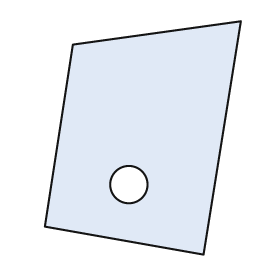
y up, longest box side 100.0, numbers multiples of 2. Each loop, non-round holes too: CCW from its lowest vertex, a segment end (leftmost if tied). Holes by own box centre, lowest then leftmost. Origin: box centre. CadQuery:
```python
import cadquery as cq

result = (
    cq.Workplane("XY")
    .moveTo(26.0, -50.0)
    .lineTo(42.0, 50.0)
    .lineTo(-30.0, 40.0)
    .lineTo(-42.0, -38.0)
    .close()
    .moveTo(-6.0, -20.0)
    .circle(8.0)
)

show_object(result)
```